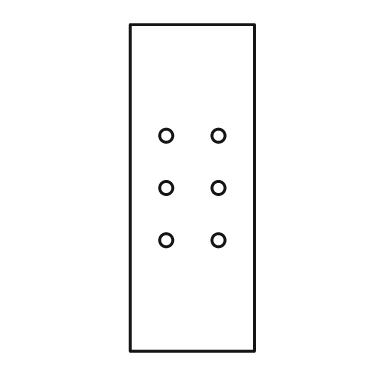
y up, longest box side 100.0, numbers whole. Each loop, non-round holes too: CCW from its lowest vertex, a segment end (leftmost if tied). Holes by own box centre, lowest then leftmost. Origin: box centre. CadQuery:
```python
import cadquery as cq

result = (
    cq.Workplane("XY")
    .moveTo(-19.0, -50.0)
    .lineTo(19.0, -50.0)
    .lineTo(19.0, 50.0)
    .lineTo(-19.0, 50.0)
    .close()
    .moveTo(-8.0, -16.0)
    .circle(2.0)
    .moveTo(8.0, -16.0)
    .circle(2.0)
    .moveTo(-8.0, 0.0)
    .circle(2.0)
    .moveTo(8.0, 0.0)
    .circle(2.0)
    .moveTo(-8.0, 16.0)
    .circle(2.0)
    .moveTo(8.0, 16.0)
    .circle(2.0)
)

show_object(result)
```